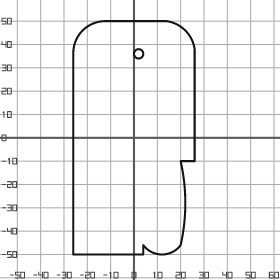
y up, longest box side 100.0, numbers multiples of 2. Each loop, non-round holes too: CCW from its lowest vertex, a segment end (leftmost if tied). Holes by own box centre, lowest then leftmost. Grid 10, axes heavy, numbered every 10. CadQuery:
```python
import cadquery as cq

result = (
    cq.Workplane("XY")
    .moveTo(-26.0, -50.0)
    .lineTo(4.0, -50.0)
    .lineTo(4.0, -46.0)
    .threePointArc((12.0, -50.0), (20.0, -46.0))
    .threePointArc((22.0, -28.0), (20.0, -10.0))
    .lineTo(26.0, -10.0)
    .lineTo(26.0, 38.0)
    .threePointArc((22.0, 46.0), (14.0, 50.0))
    .lineTo(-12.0, 50.0)
    .threePointArc((-22.0, 46.0), (-26.0, 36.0))
    .close()
    .moveTo(2.0, 36.0)
    .circle(2.0)
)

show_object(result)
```